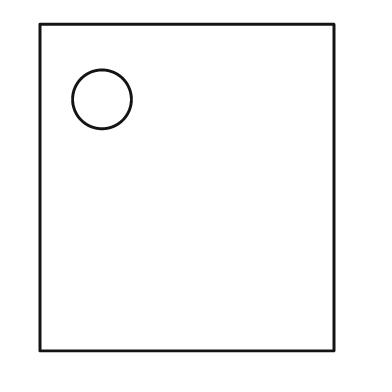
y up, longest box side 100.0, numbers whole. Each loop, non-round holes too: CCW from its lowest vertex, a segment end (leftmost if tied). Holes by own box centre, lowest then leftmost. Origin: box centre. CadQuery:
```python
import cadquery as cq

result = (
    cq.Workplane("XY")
    .moveTo(-45.0, -50.0)
    .lineTo(45.0, -50.0)
    .lineTo(45.0, 50.0)
    .lineTo(-45.0, 50.0)
    .close()
    .moveTo(-26.0, 27.0)
    .circle(9.0)
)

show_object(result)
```